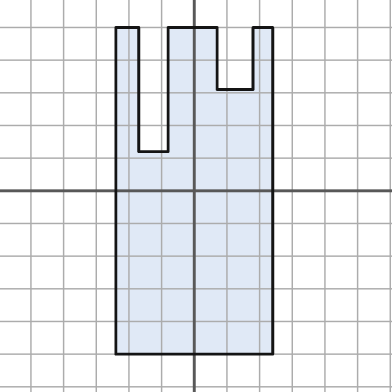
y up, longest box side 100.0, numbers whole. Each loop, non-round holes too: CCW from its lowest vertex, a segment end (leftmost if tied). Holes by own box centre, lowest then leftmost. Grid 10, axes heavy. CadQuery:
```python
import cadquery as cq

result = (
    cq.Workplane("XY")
    .moveTo(-24.0, -50.0)
    .lineTo(24.0, -50.0)
    .lineTo(24.0, 50.0)
    .lineTo(18.0, 50.0)
    .lineTo(18.0, 31.0)
    .lineTo(7.0, 31.0)
    .lineTo(7.0, 50.0)
    .lineTo(-8.0, 50.0)
    .lineTo(-8.0, 12.0)
    .lineTo(-17.0, 12.0)
    .lineTo(-17.0, 50.0)
    .lineTo(-24.0, 50.0)
    .close()
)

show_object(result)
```